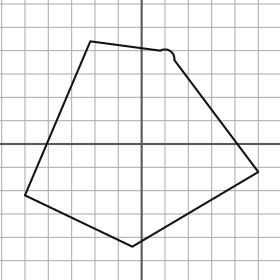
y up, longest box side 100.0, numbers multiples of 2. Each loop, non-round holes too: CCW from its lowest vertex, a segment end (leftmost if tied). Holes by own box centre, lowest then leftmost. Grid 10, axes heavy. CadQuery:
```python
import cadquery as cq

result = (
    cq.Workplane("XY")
    .moveTo(-4.0, -44.0)
    .lineTo(50.0, -12.0)
    .lineTo(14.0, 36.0)
    .threePointArc((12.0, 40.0), (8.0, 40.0))
    .lineTo(-22.0, 44.0)
    .lineTo(-50.0, -22.0)
    .close()
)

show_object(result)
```